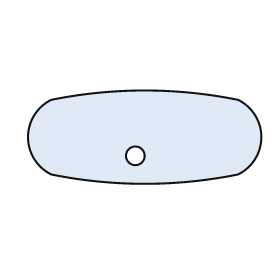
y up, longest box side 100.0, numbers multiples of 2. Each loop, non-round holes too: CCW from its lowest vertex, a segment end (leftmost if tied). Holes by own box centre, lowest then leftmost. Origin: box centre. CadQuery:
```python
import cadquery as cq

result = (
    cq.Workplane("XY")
    .moveTo(-40.0, -16.0)
    .threePointArc((0.0, -20.0), (40.0, -16.0))
    .threePointArc((50.0, 0.0), (40.0, 16.0))
    .threePointArc((0.0, 20.0), (-40.0, 16.0))
    .threePointArc((-50.0, 0.0), (-40.0, -16.0))
    .close()
    .moveTo(-4.0, -8.0)
    .circle(4.0)
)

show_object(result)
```